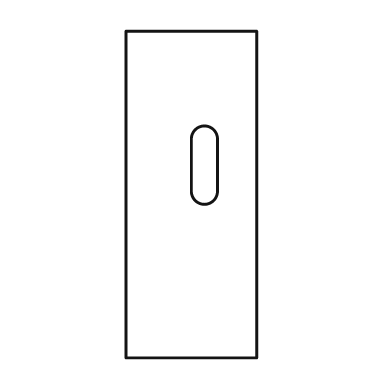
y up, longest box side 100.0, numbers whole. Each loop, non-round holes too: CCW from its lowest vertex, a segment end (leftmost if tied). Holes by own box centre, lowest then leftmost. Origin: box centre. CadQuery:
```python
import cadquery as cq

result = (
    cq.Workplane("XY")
    .moveTo(-20.0, -50.0)
    .lineTo(20.0, -50.0)
    .lineTo(20.0, 50.0)
    .lineTo(-20.0, 50.0)
    .close()
    .moveTo(0.0, 1.0)
    .threePointArc((4.0, -3.0), (8.0, 1.0))
    .lineTo(8.0, 17.0)
    .threePointArc((4.0, 21.0), (0.0, 17.0))
    .close()
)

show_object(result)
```